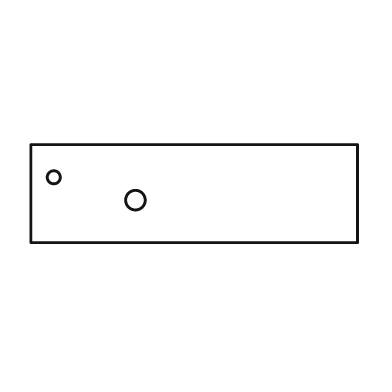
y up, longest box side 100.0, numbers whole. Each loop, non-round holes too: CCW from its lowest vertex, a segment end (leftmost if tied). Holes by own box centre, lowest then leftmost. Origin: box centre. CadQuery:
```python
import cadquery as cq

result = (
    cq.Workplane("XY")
    .moveTo(-50.0, -15.0)
    .lineTo(50.0, -15.0)
    .lineTo(50.0, 15.0)
    .lineTo(-50.0, 15.0)
    .close()
    .moveTo(-18.0, -2.0)
    .circle(3.0)
    .moveTo(-43.0, 5.0)
    .circle(2.0)
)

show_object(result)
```